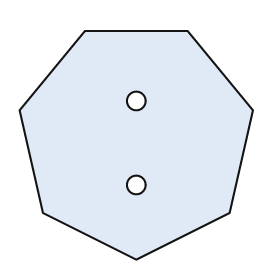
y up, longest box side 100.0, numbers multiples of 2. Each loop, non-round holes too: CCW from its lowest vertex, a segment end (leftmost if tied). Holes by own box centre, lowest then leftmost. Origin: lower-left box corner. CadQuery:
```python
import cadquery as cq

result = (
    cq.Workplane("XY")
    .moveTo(50.0, 0.0)
    .lineTo(90.0, 20.0)
    .lineTo(100.0, 64.0)
    .lineTo(72.0, 98.0)
    .lineTo(28.0, 98.0)
    .lineTo(0.0, 64.0)
    .lineTo(10.0, 20.0)
    .close()
    .moveTo(50.0, 32.0)
    .circle(4.0)
    .moveTo(50.0, 68.0)
    .circle(4.0)
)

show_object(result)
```